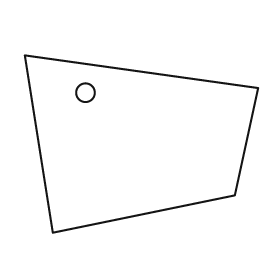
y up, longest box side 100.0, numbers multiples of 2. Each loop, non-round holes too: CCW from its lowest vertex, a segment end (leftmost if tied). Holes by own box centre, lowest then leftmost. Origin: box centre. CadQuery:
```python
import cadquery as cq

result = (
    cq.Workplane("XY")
    .moveTo(-38.0, -38.0)
    .lineTo(40.0, -22.0)
    .lineTo(50.0, 24.0)
    .lineTo(-50.0, 38.0)
    .close()
    .moveTo(-24.0, 22.0)
    .circle(4.0)
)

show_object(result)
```